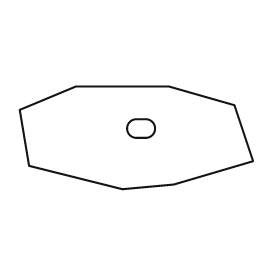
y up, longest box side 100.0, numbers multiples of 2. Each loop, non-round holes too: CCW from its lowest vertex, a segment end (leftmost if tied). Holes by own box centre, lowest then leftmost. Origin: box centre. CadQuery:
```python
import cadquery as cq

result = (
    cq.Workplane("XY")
    .moveTo(-6.0, -22.0)
    .lineTo(16.0, -20.0)
    .lineTo(50.0, -10.0)
    .lineTo(42.0, 14.0)
    .lineTo(14.0, 22.0)
    .lineTo(-26.0, 22.0)
    .lineTo(-50.0, 12.0)
    .lineTo(-46.0, -12.0)
    .close()
    .moveTo(0.0, 0.0)
    .lineTo(4.0, 0.0)
    .threePointArc((8.0, 4.0), (4.0, 8.0))
    .lineTo(0.0, 8.0)
    .threePointArc((-4.0, 4.0), (0.0, 0.0))
    .close()
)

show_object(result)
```